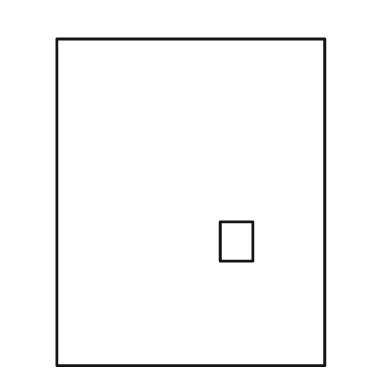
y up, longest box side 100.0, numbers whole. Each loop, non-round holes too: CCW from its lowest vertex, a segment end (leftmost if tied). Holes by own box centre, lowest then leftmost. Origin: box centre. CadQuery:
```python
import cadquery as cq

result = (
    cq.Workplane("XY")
    .moveTo(-41.0, -50.0)
    .lineTo(41.0, -50.0)
    .lineTo(41.0, 50.0)
    .lineTo(-41.0, 50.0)
    .close()
    .moveTo(9.0, -18.0)
    .lineTo(19.0, -18.0)
    .lineTo(19.0, -6.0)
    .lineTo(9.0, -6.0)
    .close()
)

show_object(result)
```